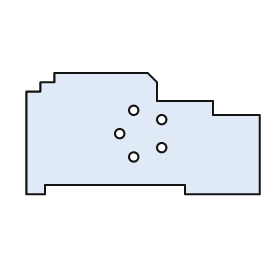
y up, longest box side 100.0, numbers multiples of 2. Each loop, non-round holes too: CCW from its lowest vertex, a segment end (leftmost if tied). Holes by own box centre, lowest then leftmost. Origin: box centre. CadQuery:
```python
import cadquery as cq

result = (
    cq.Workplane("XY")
    .moveTo(-50.0, -26.0)
    .lineTo(-42.0, -26.0)
    .lineTo(-42.0, -22.0)
    .lineTo(18.0, -22.0)
    .lineTo(18.0, -26.0)
    .lineTo(50.0, -26.0)
    .lineTo(50.0, 8.0)
    .lineTo(30.0, 8.0)
    .lineTo(30.0, 14.0)
    .lineTo(6.0, 14.0)
    .lineTo(6.0, 22.0)
    .lineTo(2.0, 26.0)
    .lineTo(-38.0, 26.0)
    .lineTo(-38.0, 22.0)
    .lineTo(-44.0, 22.0)
    .lineTo(-44.0, 18.0)
    .lineTo(-50.0, 18.0)
    .close()
    .moveTo(-4.0, -10.0)
    .circle(2.0)
    .moveTo(8.0, -6.0)
    .circle(2.0)
    .moveTo(-10.0, 0.0)
    .circle(2.0)
    .moveTo(8.0, 6.0)
    .circle(2.0)
    .moveTo(-4.0, 10.0)
    .circle(2.0)
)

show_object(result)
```